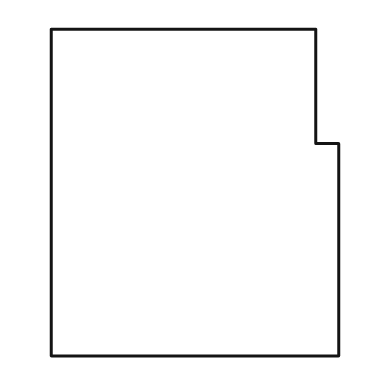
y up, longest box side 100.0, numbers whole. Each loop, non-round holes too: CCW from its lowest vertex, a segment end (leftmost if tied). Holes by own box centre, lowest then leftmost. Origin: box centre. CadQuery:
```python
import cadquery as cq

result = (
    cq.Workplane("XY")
    .moveTo(-44.0, -50.0)
    .lineTo(44.0, -50.0)
    .lineTo(44.0, 15.0)
    .lineTo(37.0, 15.0)
    .lineTo(37.0, 50.0)
    .lineTo(-44.0, 50.0)
    .close()
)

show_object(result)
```